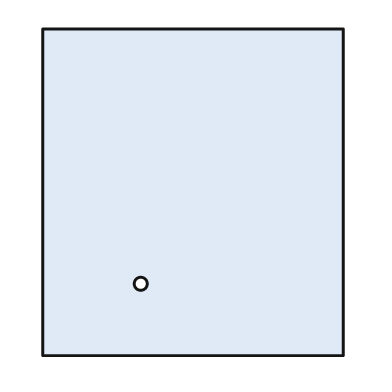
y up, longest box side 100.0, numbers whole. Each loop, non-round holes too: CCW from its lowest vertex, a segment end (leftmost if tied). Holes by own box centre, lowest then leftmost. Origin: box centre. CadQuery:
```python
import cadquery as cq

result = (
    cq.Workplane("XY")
    .moveTo(-46.0, -50.0)
    .lineTo(46.0, -50.0)
    .lineTo(46.0, 50.0)
    .lineTo(-46.0, 50.0)
    .close()
    .moveTo(-16.0, -28.0)
    .circle(2.0)
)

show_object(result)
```